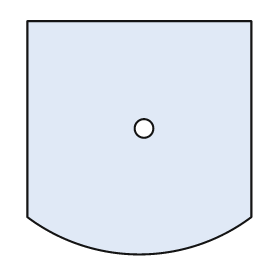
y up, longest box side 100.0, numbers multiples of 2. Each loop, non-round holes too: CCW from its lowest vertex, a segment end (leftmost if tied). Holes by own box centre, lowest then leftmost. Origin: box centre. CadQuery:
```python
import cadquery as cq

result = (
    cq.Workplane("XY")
    .moveTo(-48.0, -34.0)
    .threePointArc((0.0, -50.0), (48.0, -34.0))
    .lineTo(48.0, 50.0)
    .lineTo(-48.0, 50.0)
    .close()
    .moveTo(2.0, 4.0)
    .circle(4.0)
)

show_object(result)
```